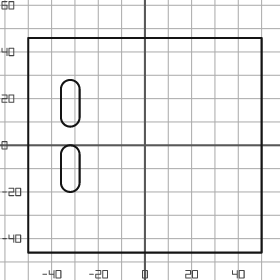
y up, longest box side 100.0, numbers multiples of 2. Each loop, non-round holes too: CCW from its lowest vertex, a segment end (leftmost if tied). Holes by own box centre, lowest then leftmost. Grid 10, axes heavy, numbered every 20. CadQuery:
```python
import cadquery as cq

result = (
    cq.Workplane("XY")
    .moveTo(-50.0, -46.0)
    .lineTo(50.0, -46.0)
    .lineTo(50.0, 46.0)
    .lineTo(-50.0, 46.0)
    .close()
    .moveTo(-36.0, -16.0)
    .threePointArc((-32.0, -20.0), (-28.0, -16.0))
    .lineTo(-28.0, -4.0)
    .threePointArc((-32.0, 0.0), (-36.0, -4.0))
    .close()
    .moveTo(-36.0, 12.0)
    .threePointArc((-32.0, 8.0), (-28.0, 12.0))
    .lineTo(-28.0, 24.0)
    .threePointArc((-32.0, 28.0), (-36.0, 24.0))
    .close()
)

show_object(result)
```